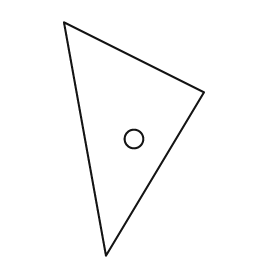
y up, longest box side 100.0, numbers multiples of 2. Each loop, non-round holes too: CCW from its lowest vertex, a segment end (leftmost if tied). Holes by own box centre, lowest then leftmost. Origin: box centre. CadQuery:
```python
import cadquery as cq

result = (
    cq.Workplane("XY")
    .moveTo(-12.0, -50.0)
    .lineTo(30.0, 20.0)
    .lineTo(-30.0, 50.0)
    .close()
    .moveTo(0.0, 0.0)
    .circle(4.0)
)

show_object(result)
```